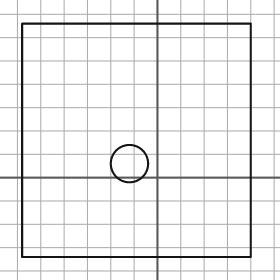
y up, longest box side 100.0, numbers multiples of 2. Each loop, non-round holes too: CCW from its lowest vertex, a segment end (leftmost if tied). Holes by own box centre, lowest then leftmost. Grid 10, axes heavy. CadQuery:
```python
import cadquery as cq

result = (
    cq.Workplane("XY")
    .moveTo(-58.0, -34.0)
    .lineTo(40.0, -34.0)
    .lineTo(40.0, 66.0)
    .lineTo(-58.0, 66.0)
    .close()
    .moveTo(-12.0, 6.0)
    .circle(8.0)
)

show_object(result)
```